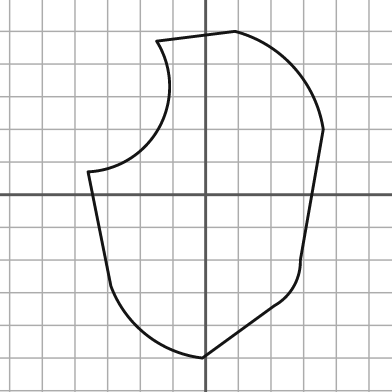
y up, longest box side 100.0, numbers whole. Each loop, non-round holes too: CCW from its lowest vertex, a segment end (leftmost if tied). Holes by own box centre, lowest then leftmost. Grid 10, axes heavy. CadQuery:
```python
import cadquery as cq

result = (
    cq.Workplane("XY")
    .moveTo(-1.0, -50.0)
    .lineTo(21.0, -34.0)
    .threePointArc((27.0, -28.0), (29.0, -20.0))
    .lineTo(36.0, 20.0)
    .threePointArc((27.0, 39.0), (9.0, 50.0))
    .lineTo(-15.0, 47.0)
    .threePointArc((-14.0, 21.0), (-36.0, 7.0))
    .lineTo(-29.0, -28.0)
    .threePointArc((-18.0, -43.0), (-1.0, -50.0))
    .close()
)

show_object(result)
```